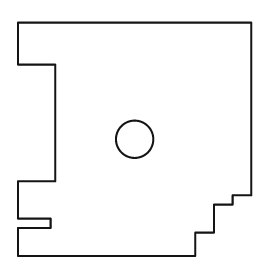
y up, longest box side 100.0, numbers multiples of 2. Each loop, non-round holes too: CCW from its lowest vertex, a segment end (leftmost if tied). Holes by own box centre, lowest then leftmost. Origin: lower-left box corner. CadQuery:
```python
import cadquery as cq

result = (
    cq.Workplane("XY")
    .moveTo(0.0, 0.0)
    .lineTo(76.0, 0.0)
    .lineTo(76.0, 10.0)
    .lineTo(84.0, 10.0)
    .lineTo(84.0, 22.0)
    .lineTo(92.0, 22.0)
    .lineTo(92.0, 26.0)
    .lineTo(100.0, 26.0)
    .lineTo(100.0, 100.0)
    .lineTo(0.0, 100.0)
    .lineTo(0.0, 82.0)
    .lineTo(16.0, 82.0)
    .lineTo(16.0, 32.0)
    .lineTo(0.0, 32.0)
    .lineTo(0.0, 16.0)
    .lineTo(14.0, 16.0)
    .lineTo(14.0, 12.0)
    .lineTo(0.0, 12.0)
    .close()
    .moveTo(50.0, 50.0)
    .circle(8.0)
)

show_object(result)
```